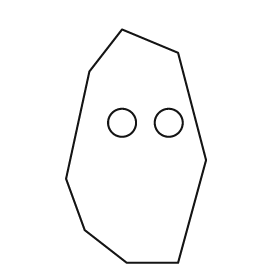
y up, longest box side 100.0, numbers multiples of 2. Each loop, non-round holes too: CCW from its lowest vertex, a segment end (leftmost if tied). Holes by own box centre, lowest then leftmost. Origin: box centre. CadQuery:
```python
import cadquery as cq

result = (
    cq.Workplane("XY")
    .moveTo(-4.0, -50.0)
    .lineTo(18.0, -50.0)
    .lineTo(30.0, -6.0)
    .lineTo(18.0, 40.0)
    .lineTo(-6.0, 50.0)
    .lineTo(-20.0, 32.0)
    .lineTo(-30.0, -14.0)
    .lineTo(-22.0, -36.0)
    .close()
    .moveTo(-6.0, 10.0)
    .circle(6.0)
    .moveTo(14.0, 10.0)
    .circle(6.0)
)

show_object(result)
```